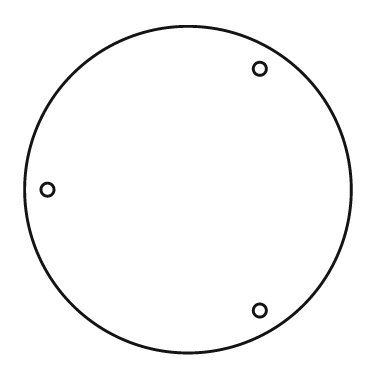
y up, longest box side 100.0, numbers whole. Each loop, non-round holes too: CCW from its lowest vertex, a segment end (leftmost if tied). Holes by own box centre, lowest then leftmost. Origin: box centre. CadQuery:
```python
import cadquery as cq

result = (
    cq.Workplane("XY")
    .moveTo(0.0, 0.0)
    .circle(50.0)
    .moveTo(22.0, -37.0)
    .circle(2.0)
    .moveTo(-43.0, 0.0)
    .circle(2.0)
    .moveTo(22.0, 37.0)
    .circle(2.0)
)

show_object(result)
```